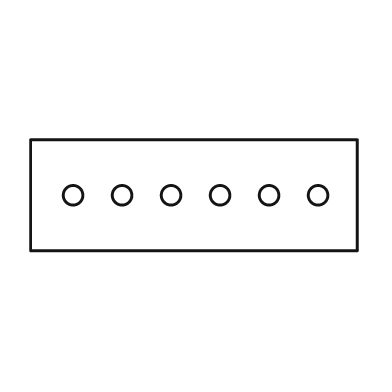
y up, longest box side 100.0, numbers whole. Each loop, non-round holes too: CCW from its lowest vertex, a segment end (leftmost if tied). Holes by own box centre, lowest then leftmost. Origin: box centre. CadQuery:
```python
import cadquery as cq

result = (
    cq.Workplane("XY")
    .moveTo(-50.0, -17.0)
    .lineTo(50.0, -17.0)
    .lineTo(50.0, 17.0)
    .lineTo(-50.0, 17.0)
    .close()
    .moveTo(-37.0, 0.0)
    .circle(3.0)
    .moveTo(-22.0, 0.0)
    .circle(3.0)
    .moveTo(-7.0, 0.0)
    .circle(3.0)
    .moveTo(8.0, 0.0)
    .circle(3.0)
    .moveTo(23.0, 0.0)
    .circle(3.0)
    .moveTo(38.0, 0.0)
    .circle(3.0)
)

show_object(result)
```